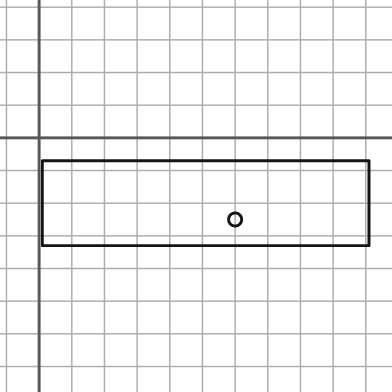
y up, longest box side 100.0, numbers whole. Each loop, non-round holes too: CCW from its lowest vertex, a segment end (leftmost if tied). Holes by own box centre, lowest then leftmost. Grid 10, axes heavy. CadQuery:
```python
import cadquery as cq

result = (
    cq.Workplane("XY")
    .moveTo(1.0, -33.0)
    .lineTo(101.0, -33.0)
    .lineTo(101.0, -7.0)
    .lineTo(1.0, -7.0)
    .close()
    .moveTo(60.0, -25.0)
    .circle(2.0)
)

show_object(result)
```